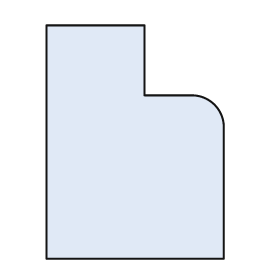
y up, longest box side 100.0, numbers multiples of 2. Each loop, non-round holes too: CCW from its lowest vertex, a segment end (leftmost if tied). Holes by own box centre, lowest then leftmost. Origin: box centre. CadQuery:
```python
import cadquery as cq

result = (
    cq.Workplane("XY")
    .moveTo(-38.0, -50.0)
    .lineTo(38.0, -50.0)
    .lineTo(38.0, 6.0)
    .threePointArc((34.0, 16.0), (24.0, 20.0))
    .lineTo(4.0, 20.0)
    .lineTo(4.0, 50.0)
    .lineTo(-38.0, 50.0)
    .close()
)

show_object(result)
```